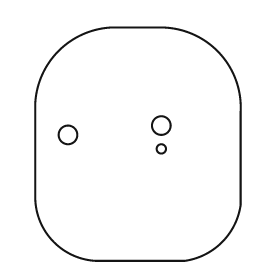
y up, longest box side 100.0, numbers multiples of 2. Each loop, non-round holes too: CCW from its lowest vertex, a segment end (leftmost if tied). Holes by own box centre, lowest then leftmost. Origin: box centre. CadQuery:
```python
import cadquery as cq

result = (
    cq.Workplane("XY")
    .moveTo(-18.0, -50.0)
    .lineTo(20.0, -50.0)
    .threePointArc((36.0, -42.0), (44.0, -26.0))
    .lineTo(44.0, 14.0)
    .threePointArc((34.0, 40.0), (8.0, 50.0))
    .lineTo(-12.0, 50.0)
    .threePointArc((-34.0, 40.0), (-44.0, 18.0))
    .lineTo(-44.0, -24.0)
    .threePointArc((-36.0, -42.0), (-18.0, -50.0))
    .close()
    .moveTo(10.0, -2.0)
    .circle(2.0)
    .moveTo(-30.0, 4.0)
    .circle(4.0)
    .moveTo(10.0, 8.0)
    .circle(4.0)
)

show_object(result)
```